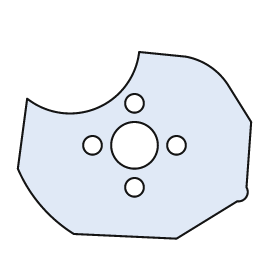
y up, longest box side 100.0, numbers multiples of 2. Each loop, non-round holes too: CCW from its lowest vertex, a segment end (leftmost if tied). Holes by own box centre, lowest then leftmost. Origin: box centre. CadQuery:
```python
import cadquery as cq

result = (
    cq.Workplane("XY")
    .moveTo(18.0, -40.0)
    .lineTo(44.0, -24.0)
    .threePointArc((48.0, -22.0), (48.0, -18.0))
    .lineTo(50.0, 10.0)
    .lineTo(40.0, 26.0)
    .threePointArc((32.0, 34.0), (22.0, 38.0))
    .lineTo(2.0, 40.0)
    .threePointArc((-16.0, 16.0), (-46.0, 20.0))
    .lineTo(-50.0, -10.0)
    .threePointArc((-40.0, -26.0), (-26.0, -38.0))
    .close()
    .moveTo(0.0, -18.0)
    .circle(4.0)
    .moveTo(-18.0, 0.0)
    .circle(4.0)
    .moveTo(0.0, 0.0)
    .circle(10.0)
    .moveTo(18.0, 0.0)
    .circle(4.0)
    .moveTo(0.0, 18.0)
    .circle(4.0)
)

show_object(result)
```